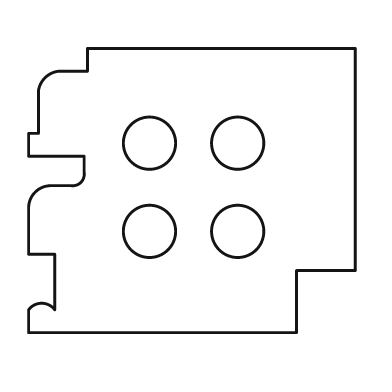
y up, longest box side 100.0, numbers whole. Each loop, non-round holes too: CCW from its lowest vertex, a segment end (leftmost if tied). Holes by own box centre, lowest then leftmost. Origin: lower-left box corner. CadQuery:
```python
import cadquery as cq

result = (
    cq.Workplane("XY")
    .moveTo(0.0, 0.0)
    .lineTo(82.0, 0.0)
    .lineTo(82.0, 19.0)
    .lineTo(100.0, 19.0)
    .lineTo(100.0, 87.0)
    .lineTo(18.0, 87.0)
    .lineTo(18.0, 80.0)
    .lineTo(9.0, 80.0)
    .threePointArc((5.0, 78.0), (3.0, 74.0))
    .lineTo(3.0, 61.0)
    .lineTo(0.0, 61.0)
    .lineTo(0.0, 54.0)
    .lineTo(17.0, 54.0)
    .lineTo(17.0, 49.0)
    .threePointArc((16.0, 46.0), (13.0, 45.0))
    .lineTo(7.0, 45.0)
    .threePointArc((2.0, 43.0), (0.0, 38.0))
    .lineTo(0.0, 24.0)
    .lineTo(8.0, 24.0)
    .lineTo(8.0, 7.0)
    .threePointArc((4.0, 9.0), (0.0, 7.0))
    .close()
    .moveTo(37.0, 31.0)
    .circle(8.0)
    .moveTo(64.0, 31.0)
    .circle(8.0)
    .moveTo(37.0, 58.0)
    .circle(8.0)
    .moveTo(64.0, 58.0)
    .circle(8.0)
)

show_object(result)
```